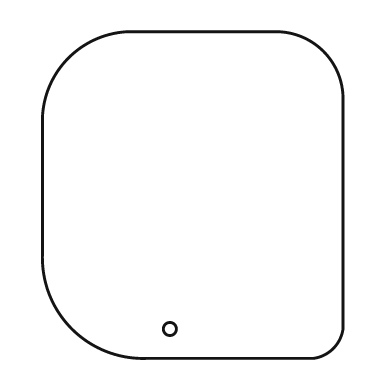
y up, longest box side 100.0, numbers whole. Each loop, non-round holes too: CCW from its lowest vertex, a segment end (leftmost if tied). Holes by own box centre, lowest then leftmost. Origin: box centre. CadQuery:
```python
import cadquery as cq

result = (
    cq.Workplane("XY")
    .moveTo(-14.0, -50.0)
    .lineTo(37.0, -50.0)
    .threePointArc((43.0, -47.0), (46.0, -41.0))
    .lineTo(46.0, 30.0)
    .threePointArc((40.0, 44.0), (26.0, 50.0))
    .lineTo(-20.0, 50.0)
    .threePointArc((-38.0, 42.0), (-46.0, 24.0))
    .lineTo(-46.0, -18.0)
    .threePointArc((-37.0, -41.0), (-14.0, -50.0))
    .close()
    .moveTo(-7.0, -41.0)
    .circle(2.0)
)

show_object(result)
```